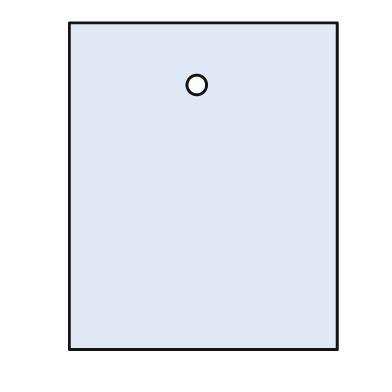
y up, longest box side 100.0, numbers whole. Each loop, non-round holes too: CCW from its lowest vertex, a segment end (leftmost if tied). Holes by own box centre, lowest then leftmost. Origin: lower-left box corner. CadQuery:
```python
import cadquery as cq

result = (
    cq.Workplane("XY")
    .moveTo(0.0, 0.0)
    .lineTo(82.0, 0.0)
    .lineTo(82.0, 100.0)
    .lineTo(0.0, 100.0)
    .close()
    .moveTo(39.0, 81.0)
    .circle(3.0)
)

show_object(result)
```